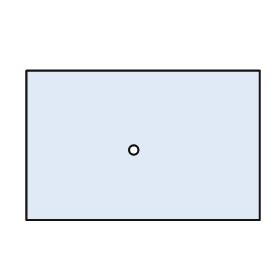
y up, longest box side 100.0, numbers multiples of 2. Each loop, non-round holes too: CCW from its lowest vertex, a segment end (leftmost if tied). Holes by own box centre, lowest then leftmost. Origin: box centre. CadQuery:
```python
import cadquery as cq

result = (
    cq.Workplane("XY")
    .moveTo(-50.0, -32.0)
    .lineTo(50.0, -32.0)
    .lineTo(50.0, 32.0)
    .lineTo(-50.0, 32.0)
    .close()
    .moveTo(-4.0, -2.0)
    .circle(2.0)
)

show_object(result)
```